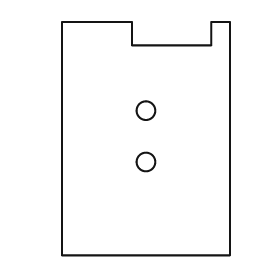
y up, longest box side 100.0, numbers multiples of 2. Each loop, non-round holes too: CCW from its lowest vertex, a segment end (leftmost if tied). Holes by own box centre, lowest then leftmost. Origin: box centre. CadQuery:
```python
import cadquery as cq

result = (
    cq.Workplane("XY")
    .moveTo(-36.0, -50.0)
    .lineTo(36.0, -50.0)
    .lineTo(36.0, 50.0)
    .lineTo(28.0, 50.0)
    .lineTo(28.0, 40.0)
    .lineTo(-6.0, 40.0)
    .lineTo(-6.0, 50.0)
    .lineTo(-36.0, 50.0)
    .close()
    .moveTo(0.0, -10.0)
    .circle(4.0)
    .moveTo(0.0, 12.0)
    .circle(4.0)
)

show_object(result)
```